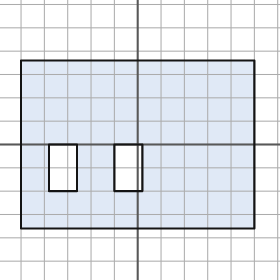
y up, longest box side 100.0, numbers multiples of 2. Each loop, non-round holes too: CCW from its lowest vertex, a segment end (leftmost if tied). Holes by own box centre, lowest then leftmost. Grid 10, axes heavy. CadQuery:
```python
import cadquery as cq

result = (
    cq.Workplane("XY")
    .moveTo(-50.0, -36.0)
    .lineTo(50.0, -36.0)
    .lineTo(50.0, 36.0)
    .lineTo(-50.0, 36.0)
    .close()
    .moveTo(-38.0, -20.0)
    .lineTo(-26.0, -20.0)
    .lineTo(-26.0, 0.0)
    .lineTo(-38.0, 0.0)
    .close()
    .moveTo(-10.0, -20.0)
    .lineTo(2.0, -20.0)
    .lineTo(2.0, 0.0)
    .lineTo(-10.0, 0.0)
    .close()
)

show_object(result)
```